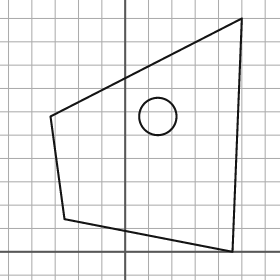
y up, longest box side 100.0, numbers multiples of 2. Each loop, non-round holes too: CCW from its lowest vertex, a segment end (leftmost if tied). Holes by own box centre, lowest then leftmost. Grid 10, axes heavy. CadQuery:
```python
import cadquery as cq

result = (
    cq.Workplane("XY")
    .moveTo(46.0, 0.0)
    .lineTo(50.0, 100.0)
    .lineTo(-32.0, 58.0)
    .lineTo(-26.0, 14.0)
    .close()
    .moveTo(14.0, 58.0)
    .circle(8.0)
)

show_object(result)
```